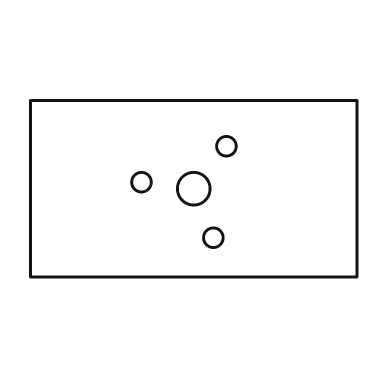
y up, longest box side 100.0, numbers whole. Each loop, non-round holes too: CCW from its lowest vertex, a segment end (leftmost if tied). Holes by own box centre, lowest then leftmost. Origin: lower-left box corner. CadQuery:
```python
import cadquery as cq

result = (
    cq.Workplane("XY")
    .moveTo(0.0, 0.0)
    .lineTo(100.0, 0.0)
    .lineTo(100.0, 54.0)
    .lineTo(0.0, 54.0)
    .close()
    .moveTo(56.0, 12.0)
    .circle(3.0)
    .moveTo(50.0, 27.0)
    .circle(5.0)
    .moveTo(34.0, 29.0)
    .circle(3.0)
    .moveTo(60.0, 40.0)
    .circle(3.0)
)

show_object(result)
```